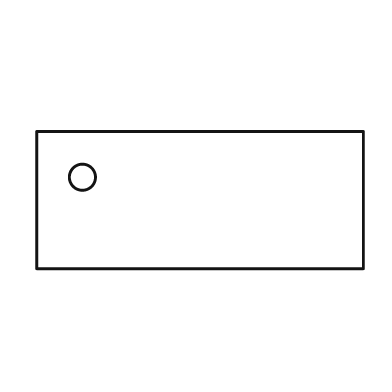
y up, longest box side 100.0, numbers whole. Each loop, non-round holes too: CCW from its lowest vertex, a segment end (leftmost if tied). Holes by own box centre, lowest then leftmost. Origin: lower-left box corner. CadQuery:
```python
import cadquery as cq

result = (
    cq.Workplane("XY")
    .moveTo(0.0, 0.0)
    .lineTo(100.0, 0.0)
    .lineTo(100.0, 42.0)
    .lineTo(0.0, 42.0)
    .close()
    .moveTo(14.0, 28.0)
    .circle(4.0)
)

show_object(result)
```